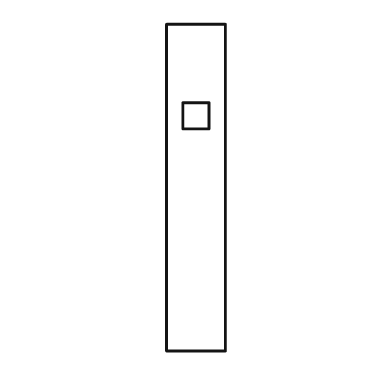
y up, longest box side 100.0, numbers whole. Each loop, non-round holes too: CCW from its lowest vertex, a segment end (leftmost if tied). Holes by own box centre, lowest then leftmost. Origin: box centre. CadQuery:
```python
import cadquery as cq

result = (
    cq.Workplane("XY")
    .moveTo(-9.0, -50.0)
    .lineTo(9.0, -50.0)
    .lineTo(9.0, 50.0)
    .lineTo(-9.0, 50.0)
    .close()
    .moveTo(-4.0, 18.0)
    .lineTo(4.0, 18.0)
    .lineTo(4.0, 26.0)
    .lineTo(-4.0, 26.0)
    .close()
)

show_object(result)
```